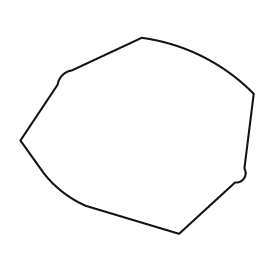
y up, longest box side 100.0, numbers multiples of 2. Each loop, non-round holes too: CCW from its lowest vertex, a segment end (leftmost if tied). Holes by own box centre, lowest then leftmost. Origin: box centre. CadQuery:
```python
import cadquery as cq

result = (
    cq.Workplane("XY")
    .moveTo(18.0, -42.0)
    .lineTo(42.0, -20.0)
    .threePointArc((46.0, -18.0), (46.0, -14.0))
    .lineTo(50.0, 18.0)
    .threePointArc((28.0, 34.0), (2.0, 42.0))
    .lineTo(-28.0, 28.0)
    .threePointArc((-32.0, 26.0), (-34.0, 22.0))
    .lineTo(-50.0, -2.0)
    .lineTo(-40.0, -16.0)
    .threePointArc((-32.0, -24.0), (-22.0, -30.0))
    .close()
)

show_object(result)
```